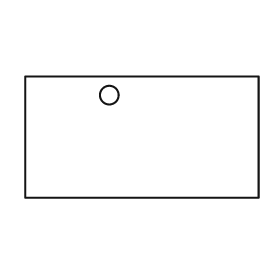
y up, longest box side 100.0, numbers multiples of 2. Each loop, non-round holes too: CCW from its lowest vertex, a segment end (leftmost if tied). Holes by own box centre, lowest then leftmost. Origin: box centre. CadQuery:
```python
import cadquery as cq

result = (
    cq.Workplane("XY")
    .moveTo(-50.0, -26.0)
    .lineTo(50.0, -26.0)
    .lineTo(50.0, 26.0)
    .lineTo(-50.0, 26.0)
    .close()
    .moveTo(-14.0, 18.0)
    .circle(4.0)
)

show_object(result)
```